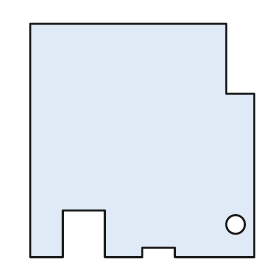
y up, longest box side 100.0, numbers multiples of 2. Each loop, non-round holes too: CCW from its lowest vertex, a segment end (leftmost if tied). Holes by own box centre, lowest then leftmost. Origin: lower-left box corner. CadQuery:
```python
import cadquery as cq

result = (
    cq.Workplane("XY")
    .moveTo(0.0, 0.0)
    .lineTo(14.0, 0.0)
    .lineTo(14.0, 20.0)
    .lineTo(32.0, 20.0)
    .lineTo(32.0, 0.0)
    .lineTo(48.0, 0.0)
    .lineTo(48.0, 4.0)
    .lineTo(62.0, 4.0)
    .lineTo(62.0, 0.0)
    .lineTo(96.0, 0.0)
    .lineTo(96.0, 70.0)
    .lineTo(84.0, 70.0)
    .lineTo(84.0, 100.0)
    .lineTo(0.0, 100.0)
    .close()
    .moveTo(88.0, 14.0)
    .circle(4.0)
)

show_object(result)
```